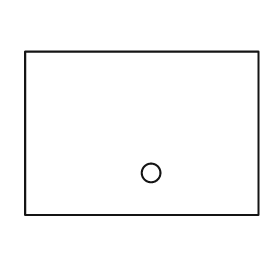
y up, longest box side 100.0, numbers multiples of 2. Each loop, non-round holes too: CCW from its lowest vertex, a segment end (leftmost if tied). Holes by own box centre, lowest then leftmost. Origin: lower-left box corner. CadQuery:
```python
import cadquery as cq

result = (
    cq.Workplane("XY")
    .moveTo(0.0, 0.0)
    .lineTo(100.0, 0.0)
    .lineTo(100.0, 70.0)
    .lineTo(0.0, 70.0)
    .close()
    .moveTo(54.0, 18.0)
    .circle(4.0)
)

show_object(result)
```